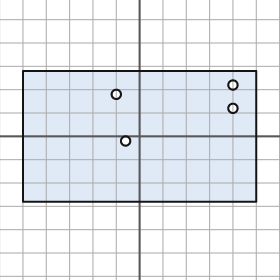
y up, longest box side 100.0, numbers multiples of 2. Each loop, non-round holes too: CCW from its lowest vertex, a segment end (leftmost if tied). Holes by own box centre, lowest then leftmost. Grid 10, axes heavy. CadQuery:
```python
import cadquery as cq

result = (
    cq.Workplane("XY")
    .moveTo(-50.0, -28.0)
    .lineTo(50.0, -28.0)
    .lineTo(50.0, 28.0)
    .lineTo(-50.0, 28.0)
    .close()
    .moveTo(-6.0, -2.0)
    .circle(2.0)
    .moveTo(40.0, 12.0)
    .circle(2.0)
    .moveTo(-10.0, 18.0)
    .circle(2.0)
    .moveTo(40.0, 22.0)
    .circle(2.0)
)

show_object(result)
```